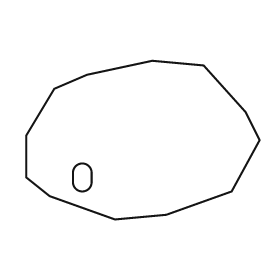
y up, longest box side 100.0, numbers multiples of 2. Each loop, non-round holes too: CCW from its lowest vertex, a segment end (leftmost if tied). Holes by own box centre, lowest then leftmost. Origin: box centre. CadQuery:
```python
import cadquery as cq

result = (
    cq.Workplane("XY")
    .moveTo(-12.0, -34.0)
    .lineTo(10.0, -32.0)
    .lineTo(38.0, -22.0)
    .lineTo(50.0, 0.0)
    .lineTo(44.0, 12.0)
    .lineTo(26.0, 32.0)
    .lineTo(4.0, 34.0)
    .lineTo(-24.0, 28.0)
    .lineTo(-38.0, 22.0)
    .lineTo(-50.0, 2.0)
    .lineTo(-50.0, -16.0)
    .lineTo(-40.0, -24.0)
    .close()
    .moveTo(-30.0, -18.0)
    .threePointArc((-26.0, -22.0), (-22.0, -18.0))
    .lineTo(-22.0, -14.0)
    .threePointArc((-26.0, -10.0), (-30.0, -14.0))
    .close()
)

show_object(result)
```